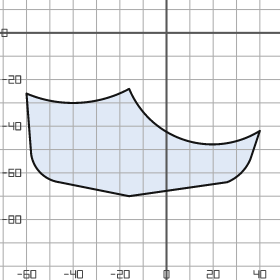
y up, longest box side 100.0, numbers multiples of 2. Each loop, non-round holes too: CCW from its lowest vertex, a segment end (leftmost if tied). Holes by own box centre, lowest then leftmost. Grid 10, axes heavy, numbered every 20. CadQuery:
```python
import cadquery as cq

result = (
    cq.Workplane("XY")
    .moveTo(-16.0, -70.0)
    .lineTo(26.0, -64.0)
    .threePointArc((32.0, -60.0), (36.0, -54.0))
    .lineTo(40.0, -42.0)
    .threePointArc((8.0, -46.0), (-16.0, -24.0))
    .threePointArc((-38.0, -30.0), (-60.0, -26.0))
    .lineTo(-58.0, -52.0)
    .threePointArc((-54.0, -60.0), (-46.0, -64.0))
    .close()
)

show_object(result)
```